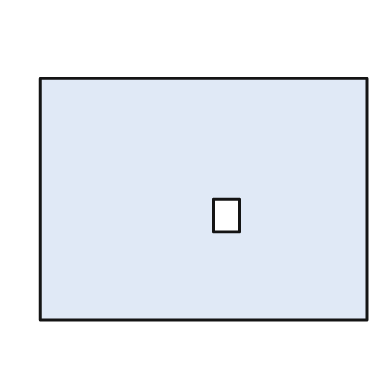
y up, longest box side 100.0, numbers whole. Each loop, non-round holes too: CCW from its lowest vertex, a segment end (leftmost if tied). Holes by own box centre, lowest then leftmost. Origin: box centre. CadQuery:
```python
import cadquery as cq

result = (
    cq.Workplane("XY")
    .moveTo(-50.0, -37.0)
    .lineTo(50.0, -37.0)
    .lineTo(50.0, 37.0)
    .lineTo(-50.0, 37.0)
    .close()
    .moveTo(3.0, -10.0)
    .lineTo(11.0, -10.0)
    .lineTo(11.0, 0.0)
    .lineTo(3.0, 0.0)
    .close()
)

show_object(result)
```